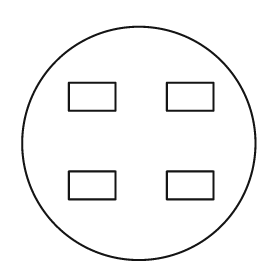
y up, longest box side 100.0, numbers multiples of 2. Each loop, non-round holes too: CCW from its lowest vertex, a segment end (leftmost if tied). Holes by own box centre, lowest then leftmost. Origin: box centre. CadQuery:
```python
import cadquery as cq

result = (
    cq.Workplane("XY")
    .moveTo(0.0, 0.0)
    .circle(50.0)
    .moveTo(-30.0, -24.0)
    .lineTo(-10.0, -24.0)
    .lineTo(-10.0, -12.0)
    .lineTo(-30.0, -12.0)
    .close()
    .moveTo(12.0, -24.0)
    .lineTo(32.0, -24.0)
    .lineTo(32.0, -12.0)
    .lineTo(12.0, -12.0)
    .close()
    .moveTo(-30.0, 14.0)
    .lineTo(-10.0, 14.0)
    .lineTo(-10.0, 26.0)
    .lineTo(-30.0, 26.0)
    .close()
    .moveTo(12.0, 14.0)
    .lineTo(32.0, 14.0)
    .lineTo(32.0, 26.0)
    .lineTo(12.0, 26.0)
    .close()
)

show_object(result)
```